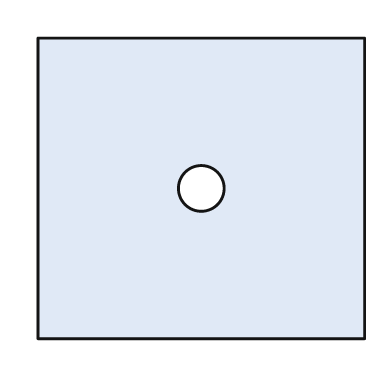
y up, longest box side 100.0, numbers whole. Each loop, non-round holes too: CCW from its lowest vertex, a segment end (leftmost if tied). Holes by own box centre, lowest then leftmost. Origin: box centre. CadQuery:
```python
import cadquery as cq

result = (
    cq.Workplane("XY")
    .moveTo(-50.0, -46.0)
    .lineTo(50.0, -46.0)
    .lineTo(50.0, 46.0)
    .lineTo(-50.0, 46.0)
    .close()
    .moveTo(0.0, 0.0)
    .circle(7.0)
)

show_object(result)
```